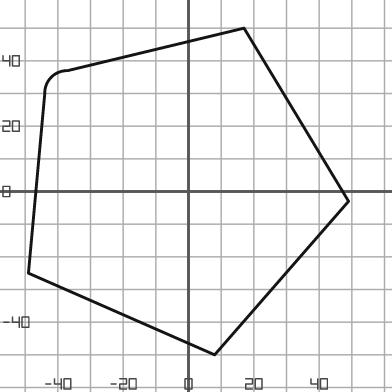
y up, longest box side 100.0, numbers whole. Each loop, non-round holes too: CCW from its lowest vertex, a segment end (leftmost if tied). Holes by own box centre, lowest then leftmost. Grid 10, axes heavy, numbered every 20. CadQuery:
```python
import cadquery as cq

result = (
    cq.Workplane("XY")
    .moveTo(8.0, -50.0)
    .lineTo(49.0, -3.0)
    .lineTo(17.0, 50.0)
    .lineTo(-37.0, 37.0)
    .threePointArc((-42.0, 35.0), (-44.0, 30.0))
    .lineTo(-49.0, -25.0)
    .close()
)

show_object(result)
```